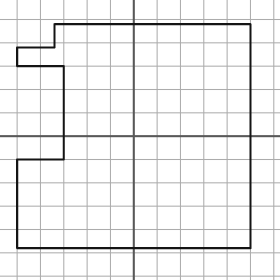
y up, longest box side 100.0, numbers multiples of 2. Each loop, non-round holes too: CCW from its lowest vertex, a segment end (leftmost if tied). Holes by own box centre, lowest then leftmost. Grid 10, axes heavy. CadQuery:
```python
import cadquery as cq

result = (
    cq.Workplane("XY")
    .moveTo(-50.0, -48.0)
    .lineTo(50.0, -48.0)
    .lineTo(50.0, 48.0)
    .lineTo(-34.0, 48.0)
    .lineTo(-34.0, 38.0)
    .lineTo(-50.0, 38.0)
    .lineTo(-50.0, 30.0)
    .lineTo(-30.0, 30.0)
    .lineTo(-30.0, -10.0)
    .lineTo(-50.0, -10.0)
    .close()
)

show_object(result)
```